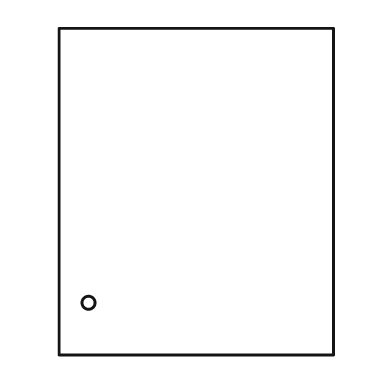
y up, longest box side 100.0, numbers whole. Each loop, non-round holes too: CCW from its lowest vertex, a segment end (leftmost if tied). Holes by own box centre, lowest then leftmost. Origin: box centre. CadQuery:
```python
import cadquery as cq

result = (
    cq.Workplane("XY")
    .moveTo(-42.0, -50.0)
    .lineTo(42.0, -50.0)
    .lineTo(42.0, 50.0)
    .lineTo(-42.0, 50.0)
    .close()
    .moveTo(-33.0, -34.0)
    .circle(2.0)
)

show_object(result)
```